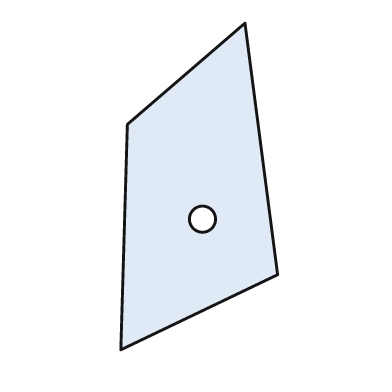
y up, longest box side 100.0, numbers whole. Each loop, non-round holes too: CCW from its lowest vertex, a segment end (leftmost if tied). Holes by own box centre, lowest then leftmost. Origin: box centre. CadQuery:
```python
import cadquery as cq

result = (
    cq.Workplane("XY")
    .moveTo(-24.0, -50.0)
    .lineTo(24.0, -27.0)
    .lineTo(14.0, 50.0)
    .lineTo(-22.0, 19.0)
    .close()
    .moveTo(1.0, -10.0)
    .circle(4.0)
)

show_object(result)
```